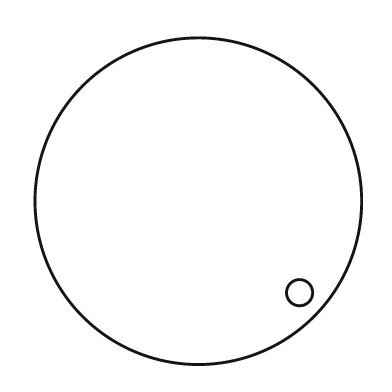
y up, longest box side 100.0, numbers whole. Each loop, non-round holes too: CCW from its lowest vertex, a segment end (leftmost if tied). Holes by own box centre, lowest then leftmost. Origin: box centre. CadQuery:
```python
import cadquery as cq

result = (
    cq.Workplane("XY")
    .moveTo(0.0, 0.0)
    .circle(50.0)
    .moveTo(31.0, -28.0)
    .circle(4.0)
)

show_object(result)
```